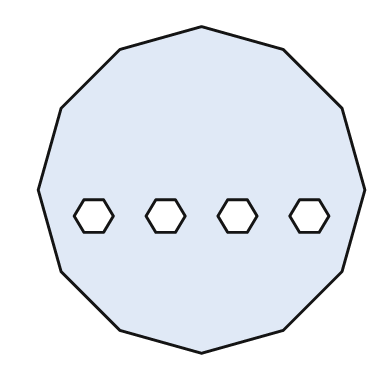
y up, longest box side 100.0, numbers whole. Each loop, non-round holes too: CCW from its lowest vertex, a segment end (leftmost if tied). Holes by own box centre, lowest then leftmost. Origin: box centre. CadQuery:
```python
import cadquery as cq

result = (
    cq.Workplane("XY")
    .moveTo(0.0, -50.0)
    .lineTo(25.0, -43.0)
    .lineTo(43.0, -25.0)
    .lineTo(50.0, 0.0)
    .lineTo(43.0, 25.0)
    .lineTo(25.0, 43.0)
    .lineTo(0.0, 50.0)
    .lineTo(-25.0, 43.0)
    .lineTo(-43.0, 25.0)
    .lineTo(-50.0, 0.0)
    .lineTo(-43.0, -25.0)
    .lineTo(-25.0, -43.0)
    .close()
    .moveTo(-36.0, -13.0)
    .lineTo(-30.0, -13.0)
    .lineTo(-27.0, -8.0)
    .lineTo(-30.0, -3.0)
    .lineTo(-36.0, -3.0)
    .lineTo(-39.0, -8.0)
    .close()
    .moveTo(-14.0, -13.0)
    .lineTo(-8.0, -13.0)
    .lineTo(-5.0, -8.0)
    .lineTo(-8.0, -3.0)
    .lineTo(-14.0, -3.0)
    .lineTo(-17.0, -8.0)
    .close()
    .moveTo(8.0, -13.0)
    .lineTo(14.0, -13.0)
    .lineTo(17.0, -8.0)
    .lineTo(14.0, -3.0)
    .lineTo(8.0, -3.0)
    .lineTo(5.0, -8.0)
    .close()
    .moveTo(30.0, -13.0)
    .lineTo(36.0, -13.0)
    .lineTo(39.0, -8.0)
    .lineTo(36.0, -3.0)
    .lineTo(30.0, -3.0)
    .lineTo(27.0, -8.0)
    .close()
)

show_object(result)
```